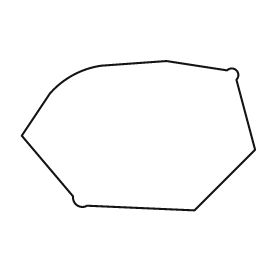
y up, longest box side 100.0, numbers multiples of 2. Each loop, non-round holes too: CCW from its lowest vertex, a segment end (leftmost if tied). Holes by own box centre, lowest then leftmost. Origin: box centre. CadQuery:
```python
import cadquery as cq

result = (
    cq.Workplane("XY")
    .moveTo(24.0, -32.0)
    .lineTo(50.0, -6.0)
    .lineTo(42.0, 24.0)
    .threePointArc((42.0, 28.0), (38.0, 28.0))
    .lineTo(12.0, 32.0)
    .lineTo(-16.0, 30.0)
    .threePointArc((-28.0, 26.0), (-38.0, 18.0))
    .lineTo(-50.0, 0.0)
    .lineTo(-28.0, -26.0)
    .threePointArc((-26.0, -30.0), (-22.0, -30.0))
    .close()
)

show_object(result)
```